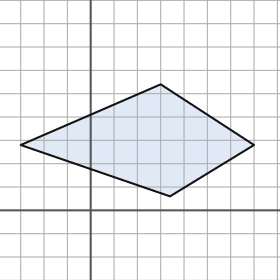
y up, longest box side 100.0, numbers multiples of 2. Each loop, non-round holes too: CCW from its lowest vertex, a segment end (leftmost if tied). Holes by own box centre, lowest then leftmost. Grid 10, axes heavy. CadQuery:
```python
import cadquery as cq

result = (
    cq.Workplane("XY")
    .moveTo(34.0, 6.0)
    .lineTo(70.0, 28.0)
    .lineTo(30.0, 54.0)
    .lineTo(-30.0, 28.0)
    .close()
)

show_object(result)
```